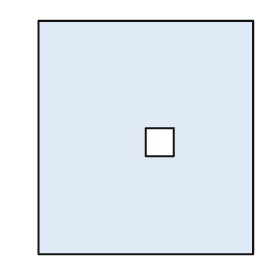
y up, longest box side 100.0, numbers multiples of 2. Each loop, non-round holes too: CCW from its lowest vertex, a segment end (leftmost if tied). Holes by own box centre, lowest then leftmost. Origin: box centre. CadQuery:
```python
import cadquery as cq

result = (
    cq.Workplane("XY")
    .moveTo(-46.0, -50.0)
    .lineTo(46.0, -50.0)
    .lineTo(46.0, 50.0)
    .lineTo(-46.0, 50.0)
    .close()
    .moveTo(0.0, -8.0)
    .lineTo(12.0, -8.0)
    .lineTo(12.0, 4.0)
    .lineTo(0.0, 4.0)
    .close()
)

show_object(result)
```